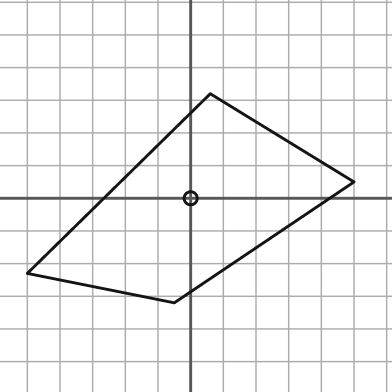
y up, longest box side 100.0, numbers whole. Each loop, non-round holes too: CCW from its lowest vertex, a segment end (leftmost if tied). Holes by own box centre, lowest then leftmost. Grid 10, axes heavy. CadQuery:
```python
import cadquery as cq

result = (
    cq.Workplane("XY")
    .moveTo(-5.0, -32.0)
    .lineTo(50.0, 5.0)
    .lineTo(6.0, 32.0)
    .lineTo(-50.0, -23.0)
    .close()
    .moveTo(0.0, 0.0)
    .circle(2.0)
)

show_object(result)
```